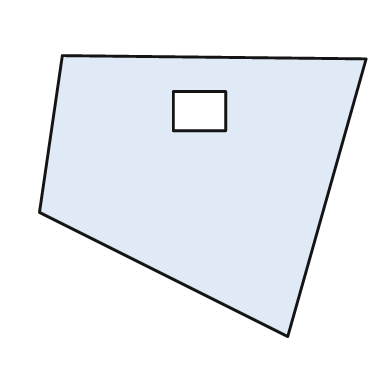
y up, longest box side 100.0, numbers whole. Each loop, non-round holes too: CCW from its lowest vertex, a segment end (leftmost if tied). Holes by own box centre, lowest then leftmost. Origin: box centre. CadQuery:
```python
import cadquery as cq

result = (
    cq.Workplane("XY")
    .moveTo(26.0, -43.0)
    .lineTo(50.0, 42.0)
    .lineTo(-43.0, 43.0)
    .lineTo(-50.0, -5.0)
    .close()
    .moveTo(-9.0, 20.0)
    .lineTo(7.0, 20.0)
    .lineTo(7.0, 32.0)
    .lineTo(-9.0, 32.0)
    .close()
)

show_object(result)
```